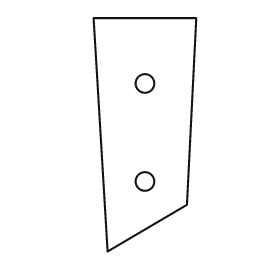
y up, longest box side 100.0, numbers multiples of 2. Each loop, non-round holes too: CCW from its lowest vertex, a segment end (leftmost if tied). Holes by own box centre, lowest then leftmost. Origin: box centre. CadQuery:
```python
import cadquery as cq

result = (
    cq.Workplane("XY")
    .moveTo(-16.0, -50.0)
    .lineTo(18.0, -30.0)
    .lineTo(22.0, 50.0)
    .lineTo(-22.0, 50.0)
    .close()
    .moveTo(0.0, -20.0)
    .circle(4.0)
    .moveTo(0.0, 22.0)
    .circle(4.0)
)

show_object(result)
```